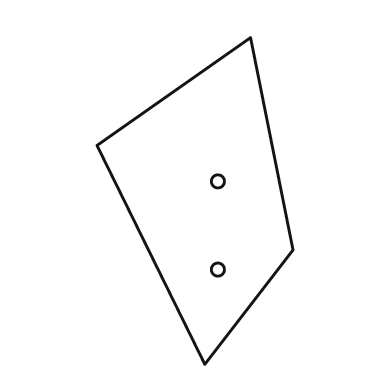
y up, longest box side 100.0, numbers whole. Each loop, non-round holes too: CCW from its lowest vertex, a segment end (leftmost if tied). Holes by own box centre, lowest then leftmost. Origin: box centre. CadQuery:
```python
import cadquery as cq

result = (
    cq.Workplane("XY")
    .moveTo(3.0, -50.0)
    .lineTo(30.0, -15.0)
    .lineTo(17.0, 50.0)
    .lineTo(-30.0, 17.0)
    .close()
    .moveTo(7.0, -21.0)
    .circle(2.0)
    .moveTo(7.0, 6.0)
    .circle(2.0)
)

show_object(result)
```